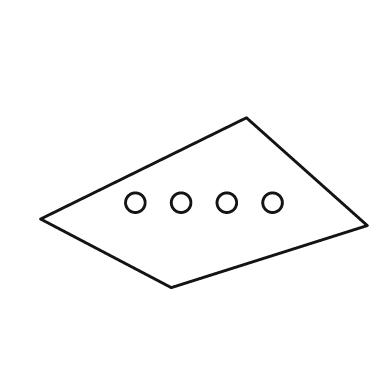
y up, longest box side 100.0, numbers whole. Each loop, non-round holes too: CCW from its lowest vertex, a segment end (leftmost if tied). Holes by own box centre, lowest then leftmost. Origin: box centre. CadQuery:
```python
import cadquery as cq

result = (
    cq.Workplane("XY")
    .moveTo(-10.0, -26.0)
    .lineTo(50.0, -7.0)
    .lineTo(13.0, 26.0)
    .lineTo(-50.0, -5.0)
    .close()
    .moveTo(-21.0, 0.0)
    .circle(3.0)
    .moveTo(-7.0, 0.0)
    .circle(3.0)
    .moveTo(7.0, 0.0)
    .circle(3.0)
    .moveTo(21.0, 0.0)
    .circle(3.0)
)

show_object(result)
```